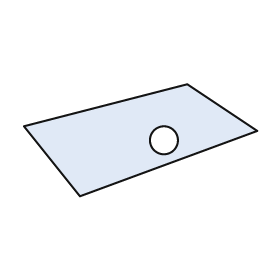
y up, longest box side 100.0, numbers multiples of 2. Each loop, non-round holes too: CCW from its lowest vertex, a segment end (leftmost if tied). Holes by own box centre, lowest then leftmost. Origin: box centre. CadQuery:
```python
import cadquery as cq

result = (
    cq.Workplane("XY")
    .moveTo(-26.0, -24.0)
    .lineTo(50.0, 4.0)
    .lineTo(20.0, 24.0)
    .lineTo(-50.0, 6.0)
    .close()
    .moveTo(10.0, 0.0)
    .circle(6.0)
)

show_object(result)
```